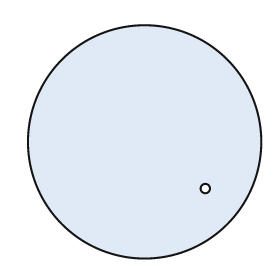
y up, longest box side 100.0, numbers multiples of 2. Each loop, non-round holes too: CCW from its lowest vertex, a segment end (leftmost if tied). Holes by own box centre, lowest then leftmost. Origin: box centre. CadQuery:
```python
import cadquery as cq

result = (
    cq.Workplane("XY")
    .moveTo(0.0, 0.0)
    .circle(50.0)
    .moveTo(26.0, -20.0)
    .circle(2.0)
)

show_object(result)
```